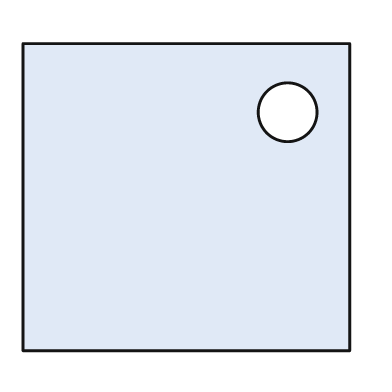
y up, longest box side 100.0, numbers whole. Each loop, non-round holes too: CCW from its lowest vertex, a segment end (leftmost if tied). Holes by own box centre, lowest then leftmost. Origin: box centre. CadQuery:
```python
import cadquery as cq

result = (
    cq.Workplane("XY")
    .moveTo(-50.0, -47.0)
    .lineTo(50.0, -47.0)
    .lineTo(50.0, 47.0)
    .lineTo(-50.0, 47.0)
    .close()
    .moveTo(31.0, 26.0)
    .circle(9.0)
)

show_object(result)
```